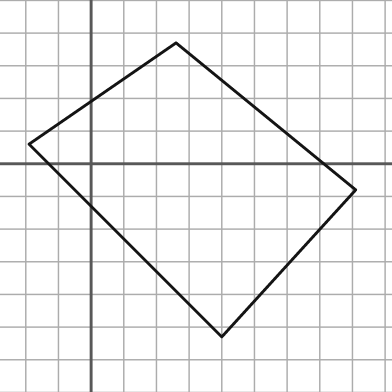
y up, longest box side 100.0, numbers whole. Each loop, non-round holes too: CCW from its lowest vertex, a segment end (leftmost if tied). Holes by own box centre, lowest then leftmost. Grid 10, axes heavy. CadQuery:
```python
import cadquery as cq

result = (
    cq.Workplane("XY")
    .moveTo(40.0, -53.0)
    .lineTo(81.0, -8.0)
    .lineTo(26.0, 37.0)
    .lineTo(-19.0, 6.0)
    .close()
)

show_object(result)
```